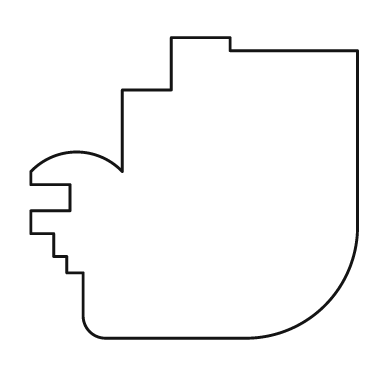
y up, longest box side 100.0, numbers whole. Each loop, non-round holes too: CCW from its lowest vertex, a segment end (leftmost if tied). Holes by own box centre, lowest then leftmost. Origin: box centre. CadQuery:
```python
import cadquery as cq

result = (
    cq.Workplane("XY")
    .moveTo(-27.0, -46.0)
    .lineTo(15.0, -46.0)
    .threePointArc((40.0, -36.0), (50.0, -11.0))
    .lineTo(50.0, 42.0)
    .lineTo(11.0, 42.0)
    .lineTo(11.0, 46.0)
    .lineTo(-7.0, 46.0)
    .lineTo(-7.0, 30.0)
    .lineTo(-22.0, 30.0)
    .lineTo(-22.0, 5.0)
    .threePointArc((-36.0, 11.0), (-50.0, 5.0))
    .lineTo(-50.0, 1.0)
    .lineTo(-38.0, 1.0)
    .lineTo(-38.0, -7.0)
    .lineTo(-50.0, -7.0)
    .lineTo(-50.0, -14.0)
    .lineTo(-43.0, -14.0)
    .lineTo(-43.0, -21.0)
    .lineTo(-39.0, -21.0)
    .lineTo(-39.0, -26.0)
    .lineTo(-34.0, -26.0)
    .lineTo(-34.0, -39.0)
    .threePointArc((-32.0, -44.0), (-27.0, -46.0))
    .close()
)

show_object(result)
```